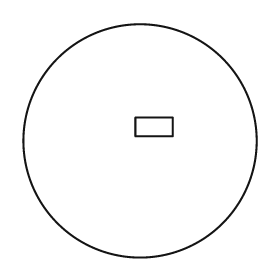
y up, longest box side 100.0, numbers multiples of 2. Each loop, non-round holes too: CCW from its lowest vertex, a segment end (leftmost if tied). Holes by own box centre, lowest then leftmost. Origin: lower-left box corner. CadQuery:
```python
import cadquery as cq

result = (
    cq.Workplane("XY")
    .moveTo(50.0, 50.0)
    .circle(50.0)
    .moveTo(48.0, 52.0)
    .lineTo(64.0, 52.0)
    .lineTo(64.0, 60.0)
    .lineTo(48.0, 60.0)
    .close()
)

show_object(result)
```